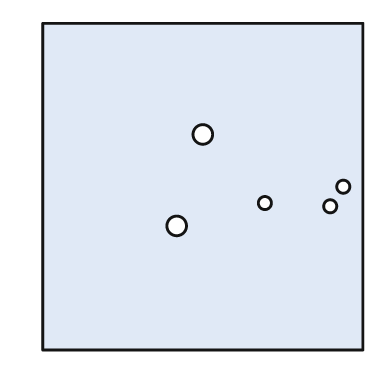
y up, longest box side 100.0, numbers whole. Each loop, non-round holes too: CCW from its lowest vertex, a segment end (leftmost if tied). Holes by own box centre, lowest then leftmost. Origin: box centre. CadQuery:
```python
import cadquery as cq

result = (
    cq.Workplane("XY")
    .moveTo(-49.0, -50.0)
    .lineTo(49.0, -50.0)
    .lineTo(49.0, 50.0)
    .lineTo(-49.0, 50.0)
    .close()
    .moveTo(-8.0, -12.0)
    .circle(3.0)
    .moveTo(39.0, -6.0)
    .circle(2.0)
    .moveTo(19.0, -5.0)
    .circle(2.0)
    .moveTo(43.0, 0.0)
    .circle(2.0)
    .moveTo(0.0, 16.0)
    .circle(3.0)
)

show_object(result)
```